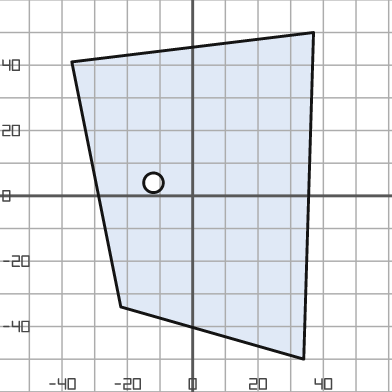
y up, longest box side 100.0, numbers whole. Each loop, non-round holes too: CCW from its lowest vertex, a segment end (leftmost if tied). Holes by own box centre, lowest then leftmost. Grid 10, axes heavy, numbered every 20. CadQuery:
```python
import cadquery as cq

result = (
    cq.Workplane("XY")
    .moveTo(34.0, -50.0)
    .lineTo(37.0, 50.0)
    .lineTo(-37.0, 41.0)
    .lineTo(-22.0, -34.0)
    .close()
    .moveTo(-12.0, 4.0)
    .circle(3.0)
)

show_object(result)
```